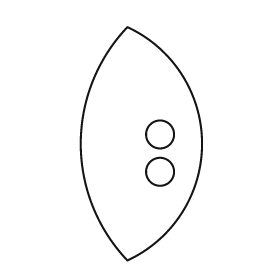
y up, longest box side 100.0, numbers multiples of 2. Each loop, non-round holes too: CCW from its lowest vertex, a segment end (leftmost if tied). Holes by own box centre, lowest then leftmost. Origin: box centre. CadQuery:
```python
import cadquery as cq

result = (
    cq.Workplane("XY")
    .moveTo(-6.0, -50.0)
    .threePointArc((26.0, 0.0), (-6.0, 50.0))
    .threePointArc((-26.0, 0.0), (-6.0, -50.0))
    .close()
    .moveTo(8.0, -12.0)
    .circle(6.0)
    .moveTo(8.0, 4.0)
    .circle(6.0)
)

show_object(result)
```